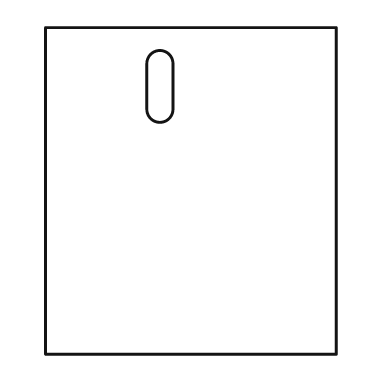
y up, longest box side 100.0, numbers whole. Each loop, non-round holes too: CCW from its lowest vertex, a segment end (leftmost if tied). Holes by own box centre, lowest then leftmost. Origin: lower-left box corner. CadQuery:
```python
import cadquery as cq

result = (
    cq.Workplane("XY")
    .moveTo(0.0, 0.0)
    .lineTo(89.0, 0.0)
    .lineTo(89.0, 100.0)
    .lineTo(0.0, 100.0)
    .close()
    .moveTo(31.0, 75.0)
    .threePointArc((35.0, 71.0), (39.0, 75.0))
    .lineTo(39.0, 89.0)
    .threePointArc((35.0, 93.0), (31.0, 89.0))
    .close()
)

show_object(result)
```